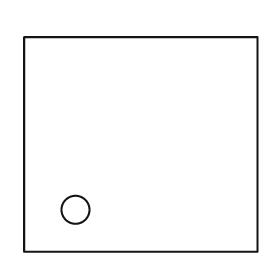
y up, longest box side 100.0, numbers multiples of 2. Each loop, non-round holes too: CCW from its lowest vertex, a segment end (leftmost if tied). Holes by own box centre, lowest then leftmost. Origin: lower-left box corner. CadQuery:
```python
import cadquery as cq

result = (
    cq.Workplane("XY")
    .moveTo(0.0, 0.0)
    .lineTo(100.0, 0.0)
    .lineTo(100.0, 92.0)
    .lineTo(0.0, 92.0)
    .close()
    .moveTo(22.0, 18.0)
    .circle(6.0)
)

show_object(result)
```